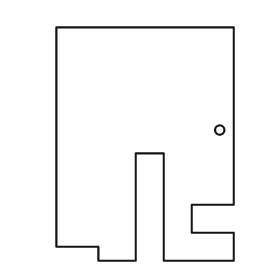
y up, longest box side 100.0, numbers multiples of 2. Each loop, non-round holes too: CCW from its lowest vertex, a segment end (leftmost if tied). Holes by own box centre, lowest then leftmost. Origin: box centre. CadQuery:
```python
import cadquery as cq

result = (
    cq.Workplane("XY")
    .moveTo(-20.0, -50.0)
    .lineTo(-4.0, -50.0)
    .lineTo(-4.0, -4.0)
    .lineTo(8.0, -4.0)
    .lineTo(8.0, -50.0)
    .lineTo(38.0, -50.0)
    .lineTo(38.0, -38.0)
    .lineTo(20.0, -38.0)
    .lineTo(20.0, -26.0)
    .lineTo(38.0, -26.0)
    .lineTo(38.0, 50.0)
    .lineTo(-38.0, 50.0)
    .lineTo(-38.0, -44.0)
    .lineTo(-20.0, -44.0)
    .close()
    .moveTo(32.0, 6.0)
    .circle(2.0)
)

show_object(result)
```